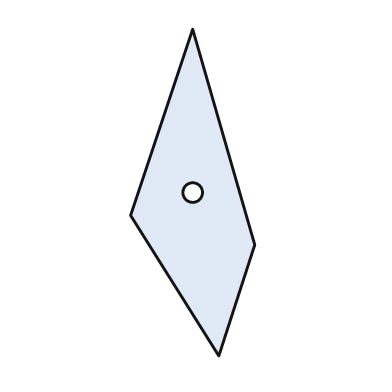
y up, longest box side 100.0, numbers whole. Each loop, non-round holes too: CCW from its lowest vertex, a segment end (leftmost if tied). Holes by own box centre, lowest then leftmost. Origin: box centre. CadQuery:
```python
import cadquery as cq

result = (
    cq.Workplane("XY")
    .moveTo(8.0, -50.0)
    .lineTo(19.0, -16.0)
    .lineTo(0.0, 50.0)
    .lineTo(-19.0, -7.0)
    .close()
    .moveTo(0.0, 0.0)
    .circle(3.0)
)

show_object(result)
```